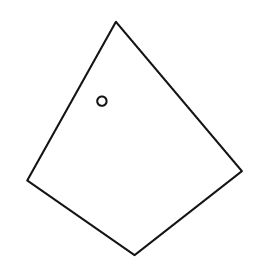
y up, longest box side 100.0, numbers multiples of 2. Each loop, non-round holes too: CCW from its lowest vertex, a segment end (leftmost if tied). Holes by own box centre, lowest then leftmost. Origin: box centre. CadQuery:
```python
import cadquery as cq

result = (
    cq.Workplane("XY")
    .moveTo(0.0, -50.0)
    .lineTo(46.0, -14.0)
    .lineTo(-8.0, 50.0)
    .lineTo(-46.0, -18.0)
    .close()
    .moveTo(-14.0, 16.0)
    .circle(2.0)
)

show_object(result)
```